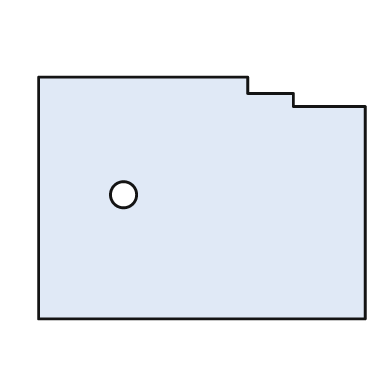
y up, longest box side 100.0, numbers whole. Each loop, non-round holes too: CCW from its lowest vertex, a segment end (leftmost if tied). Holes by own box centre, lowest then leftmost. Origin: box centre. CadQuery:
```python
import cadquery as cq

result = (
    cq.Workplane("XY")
    .moveTo(-50.0, -37.0)
    .lineTo(50.0, -37.0)
    .lineTo(50.0, 28.0)
    .lineTo(28.0, 28.0)
    .lineTo(28.0, 32.0)
    .lineTo(14.0, 32.0)
    .lineTo(14.0, 37.0)
    .lineTo(-50.0, 37.0)
    .close()
    .moveTo(-24.0, 1.0)
    .circle(4.0)
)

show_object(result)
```